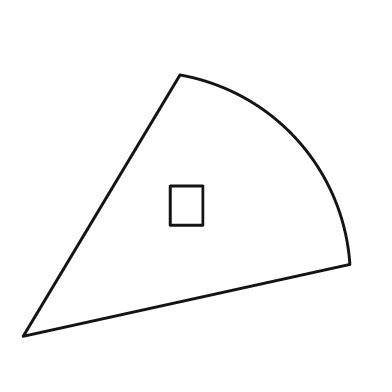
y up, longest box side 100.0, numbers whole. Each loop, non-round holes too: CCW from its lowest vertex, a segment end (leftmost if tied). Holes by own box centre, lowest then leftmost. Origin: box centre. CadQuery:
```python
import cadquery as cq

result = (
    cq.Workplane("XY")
    .moveTo(-50.0, -40.0)
    .lineTo(50.0, -18.0)
    .threePointArc((34.0, 20.0), (-2.0, 40.0))
    .close()
    .moveTo(-5.0, -6.0)
    .lineTo(5.0, -6.0)
    .lineTo(5.0, 6.0)
    .lineTo(-5.0, 6.0)
    .close()
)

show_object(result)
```